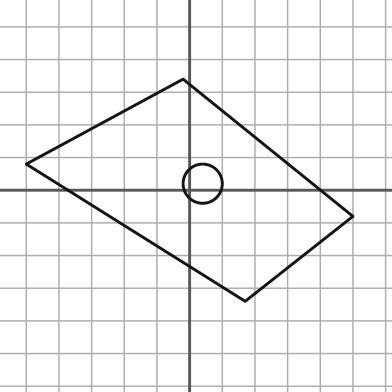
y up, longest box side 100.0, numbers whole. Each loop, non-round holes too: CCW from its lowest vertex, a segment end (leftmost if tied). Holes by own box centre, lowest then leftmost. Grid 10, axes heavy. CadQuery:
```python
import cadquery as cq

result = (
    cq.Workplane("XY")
    .moveTo(17.0, -34.0)
    .lineTo(50.0, -8.0)
    .lineTo(-2.0, 34.0)
    .lineTo(-50.0, 8.0)
    .close()
    .moveTo(4.0, 2.0)
    .circle(6.0)
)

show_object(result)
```